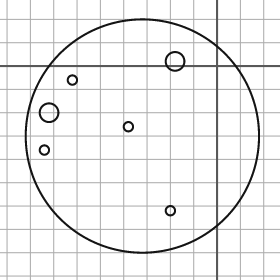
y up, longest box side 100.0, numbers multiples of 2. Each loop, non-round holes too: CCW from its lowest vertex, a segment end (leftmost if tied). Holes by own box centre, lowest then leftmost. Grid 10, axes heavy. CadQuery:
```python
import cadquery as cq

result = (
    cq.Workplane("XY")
    .moveTo(-32.0, -30.0)
    .circle(50.0)
    .moveTo(-20.0, -62.0)
    .circle(2.0)
    .moveTo(-74.0, -36.0)
    .circle(2.0)
    .moveTo(-38.0, -26.0)
    .circle(2.0)
    .moveTo(-72.0, -20.0)
    .circle(4.0)
    .moveTo(-62.0, -6.0)
    .circle(2.0)
    .moveTo(-18.0, 2.0)
    .circle(4.0)
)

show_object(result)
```